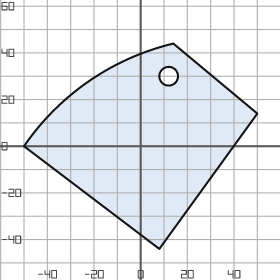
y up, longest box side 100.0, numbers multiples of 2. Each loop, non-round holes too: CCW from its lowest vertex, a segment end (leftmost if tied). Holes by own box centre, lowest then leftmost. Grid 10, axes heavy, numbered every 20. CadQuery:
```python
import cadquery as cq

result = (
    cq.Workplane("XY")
    .moveTo(8.0, -44.0)
    .lineTo(50.0, 14.0)
    .lineTo(14.0, 44.0)
    .threePointArc((-22.0, 28.0), (-50.0, 0.0))
    .close()
    .moveTo(12.0, 30.0)
    .circle(4.0)
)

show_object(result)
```